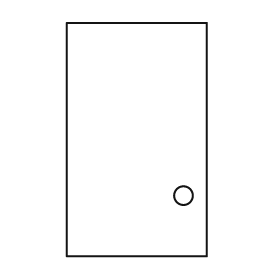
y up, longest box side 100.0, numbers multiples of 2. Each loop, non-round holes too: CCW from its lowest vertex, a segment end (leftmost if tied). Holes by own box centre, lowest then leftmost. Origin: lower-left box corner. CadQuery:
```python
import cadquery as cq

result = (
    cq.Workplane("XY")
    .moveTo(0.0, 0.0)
    .lineTo(60.0, 0.0)
    .lineTo(60.0, 100.0)
    .lineTo(0.0, 100.0)
    .close()
    .moveTo(50.0, 26.0)
    .circle(4.0)
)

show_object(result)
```